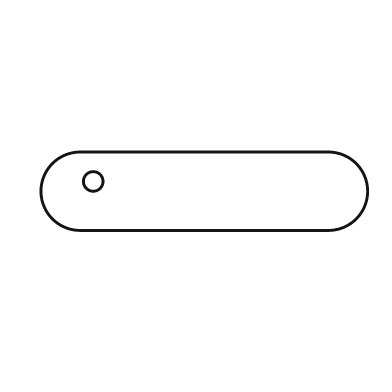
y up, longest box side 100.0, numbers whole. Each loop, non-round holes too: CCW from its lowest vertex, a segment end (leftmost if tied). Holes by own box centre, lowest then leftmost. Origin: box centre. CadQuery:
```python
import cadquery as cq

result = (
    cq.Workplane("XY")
    .moveTo(-38.0, -12.0)
    .lineTo(38.0, -12.0)
    .threePointArc((50.0, 0.0), (38.0, 12.0))
    .lineTo(-38.0, 12.0)
    .threePointArc((-50.0, 0.0), (-38.0, -12.0))
    .close()
    .moveTo(-34.0, 3.0)
    .circle(3.0)
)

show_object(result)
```